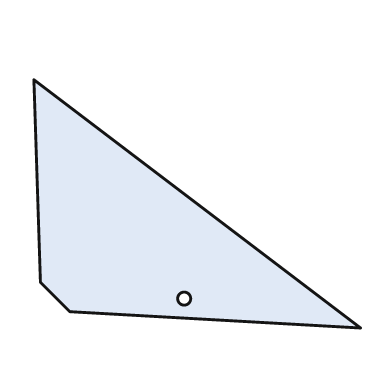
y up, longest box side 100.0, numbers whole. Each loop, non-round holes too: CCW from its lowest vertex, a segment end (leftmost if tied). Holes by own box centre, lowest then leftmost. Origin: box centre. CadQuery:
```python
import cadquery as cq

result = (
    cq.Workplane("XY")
    .moveTo(50.0, -38.0)
    .lineTo(-50.0, 38.0)
    .lineTo(-48.0, -24.0)
    .lineTo(-39.0, -33.0)
    .close()
    .moveTo(-4.0, -29.0)
    .circle(2.0)
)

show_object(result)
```